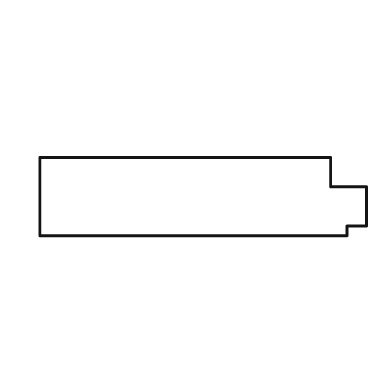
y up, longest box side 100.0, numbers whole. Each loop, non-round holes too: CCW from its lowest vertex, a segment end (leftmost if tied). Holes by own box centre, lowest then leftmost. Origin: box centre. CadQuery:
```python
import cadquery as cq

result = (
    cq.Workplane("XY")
    .moveTo(-50.0, -12.0)
    .lineTo(44.0, -12.0)
    .lineTo(44.0, -9.0)
    .lineTo(50.0, -9.0)
    .lineTo(50.0, 3.0)
    .lineTo(39.0, 3.0)
    .lineTo(39.0, 12.0)
    .lineTo(-50.0, 12.0)
    .close()
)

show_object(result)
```